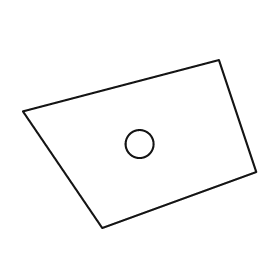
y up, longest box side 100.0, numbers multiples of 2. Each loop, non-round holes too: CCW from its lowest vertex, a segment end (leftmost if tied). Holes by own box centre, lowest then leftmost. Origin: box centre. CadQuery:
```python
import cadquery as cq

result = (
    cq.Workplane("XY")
    .moveTo(-16.0, -36.0)
    .lineTo(50.0, -12.0)
    .lineTo(34.0, 36.0)
    .lineTo(-50.0, 14.0)
    .close()
    .moveTo(0.0, 0.0)
    .circle(6.0)
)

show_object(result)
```